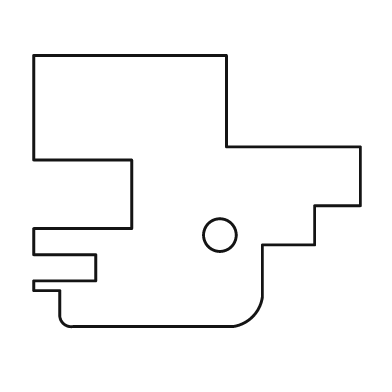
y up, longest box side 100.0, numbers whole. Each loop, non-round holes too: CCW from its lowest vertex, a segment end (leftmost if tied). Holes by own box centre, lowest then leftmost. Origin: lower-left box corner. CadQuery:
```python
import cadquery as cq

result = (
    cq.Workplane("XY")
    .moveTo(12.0, 0.0)
    .lineTo(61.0, 0.0)
    .threePointArc((67.0, 3.0), (70.0, 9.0))
    .lineTo(70.0, 25.0)
    .lineTo(86.0, 25.0)
    .lineTo(86.0, 37.0)
    .lineTo(100.0, 37.0)
    .lineTo(100.0, 55.0)
    .lineTo(59.0, 55.0)
    .lineTo(59.0, 83.0)
    .lineTo(0.0, 83.0)
    .lineTo(0.0, 51.0)
    .lineTo(30.0, 51.0)
    .lineTo(30.0, 30.0)
    .lineTo(0.0, 30.0)
    .lineTo(0.0, 22.0)
    .lineTo(19.0, 22.0)
    .lineTo(19.0, 14.0)
    .lineTo(0.0, 14.0)
    .lineTo(0.0, 11.0)
    .lineTo(8.0, 11.0)
    .lineTo(8.0, 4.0)
    .threePointArc((9.0, 1.0), (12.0, 0.0))
    .close()
    .moveTo(57.0, 28.0)
    .circle(5.0)
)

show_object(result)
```